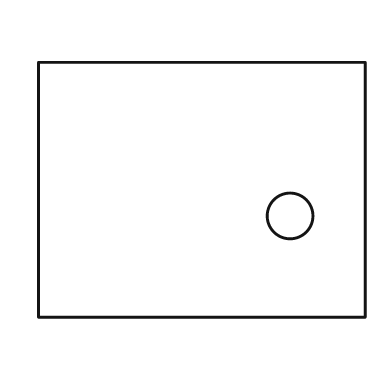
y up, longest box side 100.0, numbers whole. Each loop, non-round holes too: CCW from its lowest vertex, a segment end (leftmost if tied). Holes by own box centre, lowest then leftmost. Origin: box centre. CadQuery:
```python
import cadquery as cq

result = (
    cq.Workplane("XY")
    .moveTo(-50.0, -39.0)
    .lineTo(50.0, -39.0)
    .lineTo(50.0, 39.0)
    .lineTo(-50.0, 39.0)
    .close()
    .moveTo(27.0, -8.0)
    .circle(7.0)
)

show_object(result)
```